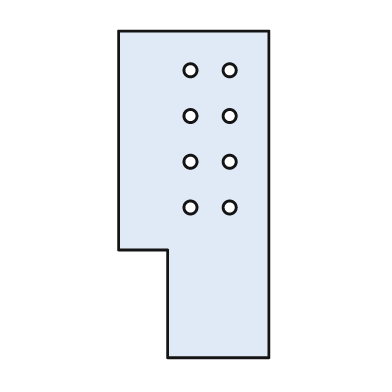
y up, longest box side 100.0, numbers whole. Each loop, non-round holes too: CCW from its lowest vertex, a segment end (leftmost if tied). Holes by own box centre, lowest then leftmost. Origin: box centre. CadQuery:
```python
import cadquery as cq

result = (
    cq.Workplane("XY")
    .moveTo(-8.0, -50.0)
    .lineTo(23.0, -50.0)
    .lineTo(23.0, 50.0)
    .lineTo(-23.0, 50.0)
    .lineTo(-23.0, -17.0)
    .lineTo(-8.0, -17.0)
    .close()
    .moveTo(-1.0, -4.0)
    .circle(2.0)
    .moveTo(11.0, -4.0)
    .circle(2.0)
    .moveTo(-1.0, 10.0)
    .circle(2.0)
    .moveTo(11.0, 10.0)
    .circle(2.0)
    .moveTo(-1.0, 24.0)
    .circle(2.0)
    .moveTo(11.0, 24.0)
    .circle(2.0)
    .moveTo(-1.0, 38.0)
    .circle(2.0)
    .moveTo(11.0, 38.0)
    .circle(2.0)
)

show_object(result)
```